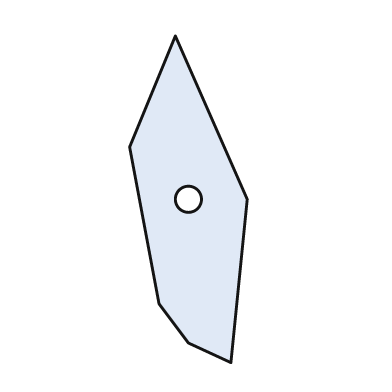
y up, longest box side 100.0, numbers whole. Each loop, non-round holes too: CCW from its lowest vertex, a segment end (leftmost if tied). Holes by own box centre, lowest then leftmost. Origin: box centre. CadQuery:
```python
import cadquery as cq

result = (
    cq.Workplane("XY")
    .moveTo(13.0, -50.0)
    .lineTo(18.0, 0.0)
    .lineTo(-4.0, 50.0)
    .lineTo(-18.0, 16.0)
    .lineTo(-9.0, -32.0)
    .lineTo(0.0, -44.0)
    .close()
    .moveTo(0.0, 0.0)
    .circle(4.0)
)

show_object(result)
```